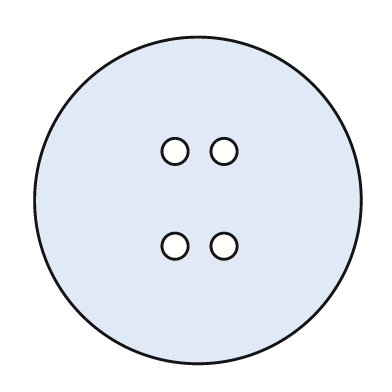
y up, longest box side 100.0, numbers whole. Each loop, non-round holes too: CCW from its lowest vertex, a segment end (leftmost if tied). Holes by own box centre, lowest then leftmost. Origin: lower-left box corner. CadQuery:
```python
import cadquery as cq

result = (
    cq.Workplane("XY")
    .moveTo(50.0, 50.0)
    .circle(50.0)
    .moveTo(43.0, 36.0)
    .circle(4.0)
    .moveTo(58.0, 36.0)
    .circle(4.0)
    .moveTo(43.0, 65.0)
    .circle(4.0)
    .moveTo(58.0, 65.0)
    .circle(4.0)
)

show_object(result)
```